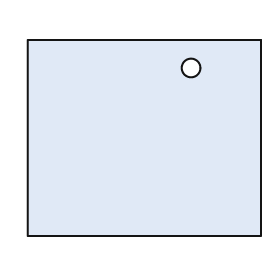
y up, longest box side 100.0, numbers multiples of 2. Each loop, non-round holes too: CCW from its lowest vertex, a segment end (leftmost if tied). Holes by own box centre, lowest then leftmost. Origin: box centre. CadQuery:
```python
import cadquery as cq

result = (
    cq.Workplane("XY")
    .moveTo(-50.0, -42.0)
    .lineTo(50.0, -42.0)
    .lineTo(50.0, 42.0)
    .lineTo(-50.0, 42.0)
    .close()
    .moveTo(20.0, 30.0)
    .circle(4.0)
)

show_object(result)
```